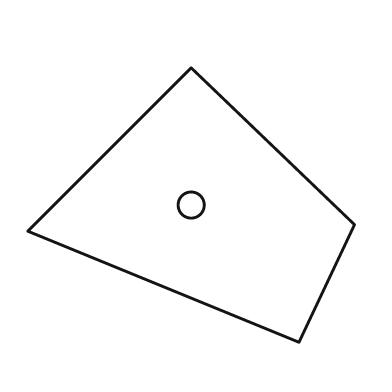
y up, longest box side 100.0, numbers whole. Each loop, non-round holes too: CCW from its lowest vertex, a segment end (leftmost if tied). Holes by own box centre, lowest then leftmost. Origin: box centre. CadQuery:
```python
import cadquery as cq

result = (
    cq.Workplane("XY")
    .moveTo(33.0, -42.0)
    .lineTo(50.0, -6.0)
    .lineTo(0.0, 42.0)
    .lineTo(-50.0, -8.0)
    .close()
    .moveTo(0.0, 0.0)
    .circle(4.0)
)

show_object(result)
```